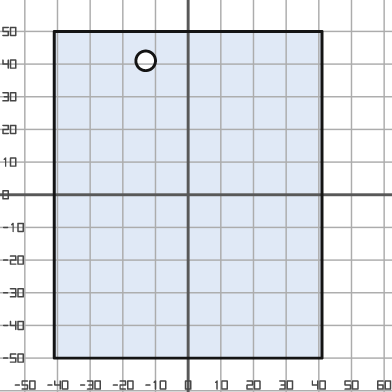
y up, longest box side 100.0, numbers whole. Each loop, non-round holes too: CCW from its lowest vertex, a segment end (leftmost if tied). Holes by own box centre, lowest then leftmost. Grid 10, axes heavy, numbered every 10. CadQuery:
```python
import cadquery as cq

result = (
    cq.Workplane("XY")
    .moveTo(-41.0, -50.0)
    .lineTo(41.0, -50.0)
    .lineTo(41.0, 50.0)
    .lineTo(-41.0, 50.0)
    .close()
    .moveTo(-13.0, 41.0)
    .circle(3.0)
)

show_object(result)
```